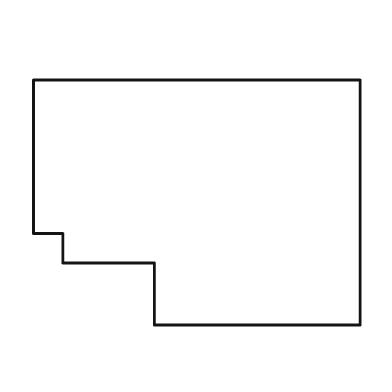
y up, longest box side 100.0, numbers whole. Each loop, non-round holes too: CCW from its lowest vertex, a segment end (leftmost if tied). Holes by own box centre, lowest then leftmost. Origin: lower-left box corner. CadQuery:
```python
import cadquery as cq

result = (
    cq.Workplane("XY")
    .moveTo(37.0, 0.0)
    .lineTo(100.0, 0.0)
    .lineTo(100.0, 75.0)
    .lineTo(0.0, 75.0)
    .lineTo(0.0, 28.0)
    .lineTo(9.0, 28.0)
    .lineTo(9.0, 19.0)
    .lineTo(37.0, 19.0)
    .close()
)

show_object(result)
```